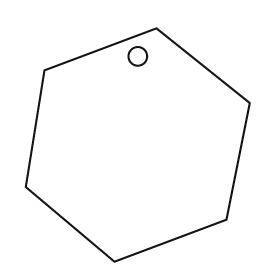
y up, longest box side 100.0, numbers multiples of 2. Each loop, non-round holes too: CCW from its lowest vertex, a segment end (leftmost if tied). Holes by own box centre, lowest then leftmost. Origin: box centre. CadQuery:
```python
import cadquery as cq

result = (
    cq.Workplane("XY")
    .moveTo(-10.0, -50.0)
    .lineTo(38.0, -32.0)
    .lineTo(48.0, 18.0)
    .lineTo(8.0, 50.0)
    .lineTo(-40.0, 32.0)
    .lineTo(-48.0, -18.0)
    .close()
    .moveTo(0.0, 38.0)
    .circle(4.0)
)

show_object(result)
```